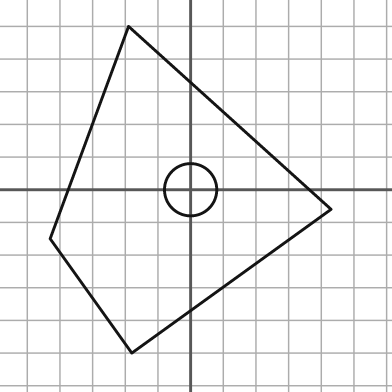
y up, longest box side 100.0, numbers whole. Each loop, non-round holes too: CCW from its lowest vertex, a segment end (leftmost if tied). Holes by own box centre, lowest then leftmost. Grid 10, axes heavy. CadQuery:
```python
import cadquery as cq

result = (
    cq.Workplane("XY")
    .moveTo(-18.0, -50.0)
    .lineTo(43.0, -6.0)
    .lineTo(-19.0, 50.0)
    .lineTo(-43.0, -15.0)
    .close()
    .moveTo(0.0, 0.0)
    .circle(8.0)
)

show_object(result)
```